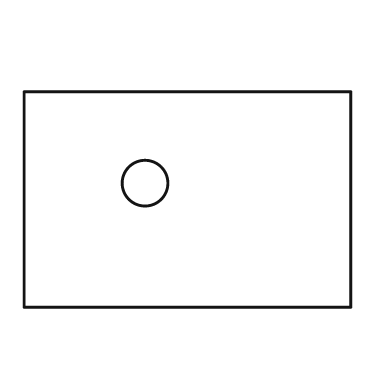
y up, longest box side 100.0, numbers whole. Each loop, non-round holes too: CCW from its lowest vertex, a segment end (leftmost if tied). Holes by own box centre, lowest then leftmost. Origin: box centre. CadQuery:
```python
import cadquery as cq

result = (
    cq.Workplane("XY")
    .moveTo(-50.0, -33.0)
    .lineTo(50.0, -33.0)
    .lineTo(50.0, 33.0)
    .lineTo(-50.0, 33.0)
    .close()
    .moveTo(-13.0, 5.0)
    .circle(7.0)
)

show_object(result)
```